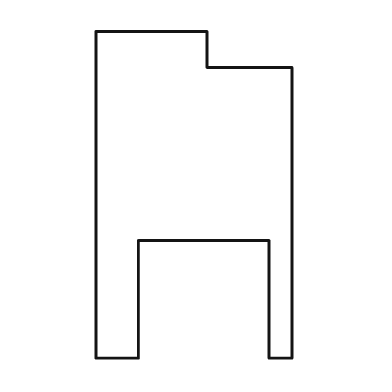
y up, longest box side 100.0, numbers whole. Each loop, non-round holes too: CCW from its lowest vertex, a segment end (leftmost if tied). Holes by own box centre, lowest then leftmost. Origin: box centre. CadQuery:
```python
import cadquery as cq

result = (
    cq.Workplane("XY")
    .moveTo(-30.0, -50.0)
    .lineTo(-17.0, -50.0)
    .lineTo(-17.0, -14.0)
    .lineTo(23.0, -14.0)
    .lineTo(23.0, -50.0)
    .lineTo(30.0, -50.0)
    .lineTo(30.0, 39.0)
    .lineTo(4.0, 39.0)
    .lineTo(4.0, 50.0)
    .lineTo(-30.0, 50.0)
    .close()
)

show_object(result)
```